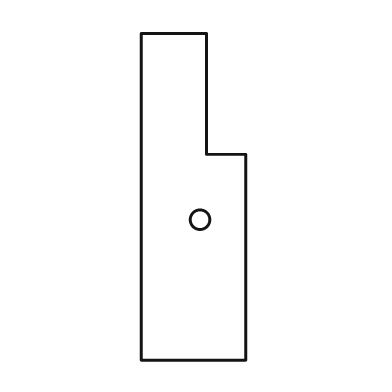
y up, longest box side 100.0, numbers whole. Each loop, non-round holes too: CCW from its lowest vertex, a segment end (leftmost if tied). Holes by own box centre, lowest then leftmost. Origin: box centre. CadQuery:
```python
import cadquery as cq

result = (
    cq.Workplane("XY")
    .moveTo(-16.0, -50.0)
    .lineTo(16.0, -50.0)
    .lineTo(16.0, 13.0)
    .lineTo(4.0, 13.0)
    .lineTo(4.0, 50.0)
    .lineTo(-16.0, 50.0)
    .close()
    .moveTo(2.0, -7.0)
    .circle(3.0)
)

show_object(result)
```